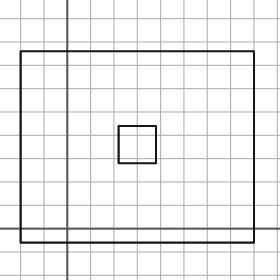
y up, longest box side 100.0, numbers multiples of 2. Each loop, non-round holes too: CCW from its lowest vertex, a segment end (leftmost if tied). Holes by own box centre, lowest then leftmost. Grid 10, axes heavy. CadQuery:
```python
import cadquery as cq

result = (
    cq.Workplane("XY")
    .moveTo(-20.0, -6.0)
    .lineTo(80.0, -6.0)
    .lineTo(80.0, 76.0)
    .lineTo(-20.0, 76.0)
    .close()
    .moveTo(22.0, 28.0)
    .lineTo(38.0, 28.0)
    .lineTo(38.0, 44.0)
    .lineTo(22.0, 44.0)
    .close()
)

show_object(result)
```